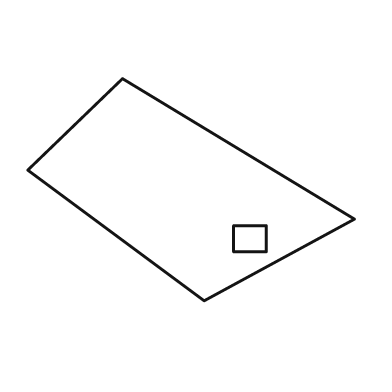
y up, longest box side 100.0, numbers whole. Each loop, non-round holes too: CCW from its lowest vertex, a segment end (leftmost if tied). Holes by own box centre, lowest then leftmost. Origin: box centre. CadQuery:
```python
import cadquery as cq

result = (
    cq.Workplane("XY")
    .moveTo(4.0, -34.0)
    .lineTo(50.0, -9.0)
    .lineTo(-21.0, 34.0)
    .lineTo(-50.0, 6.0)
    .close()
    .moveTo(13.0, -19.0)
    .lineTo(23.0, -19.0)
    .lineTo(23.0, -11.0)
    .lineTo(13.0, -11.0)
    .close()
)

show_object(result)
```